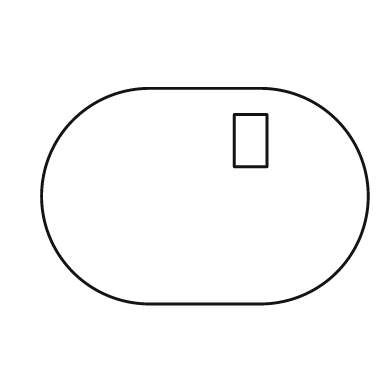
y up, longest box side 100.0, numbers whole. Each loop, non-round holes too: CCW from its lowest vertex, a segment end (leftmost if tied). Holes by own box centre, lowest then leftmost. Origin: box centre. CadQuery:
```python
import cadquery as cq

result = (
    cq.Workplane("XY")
    .moveTo(-17.0, -33.0)
    .lineTo(17.0, -33.0)
    .threePointArc((50.0, 0.0), (17.0, 33.0))
    .lineTo(-17.0, 33.0)
    .threePointArc((-50.0, 0.0), (-17.0, -33.0))
    .close()
    .moveTo(9.0, 9.0)
    .lineTo(19.0, 9.0)
    .lineTo(19.0, 25.0)
    .lineTo(9.0, 25.0)
    .close()
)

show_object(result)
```